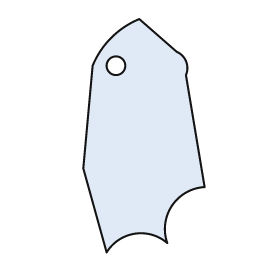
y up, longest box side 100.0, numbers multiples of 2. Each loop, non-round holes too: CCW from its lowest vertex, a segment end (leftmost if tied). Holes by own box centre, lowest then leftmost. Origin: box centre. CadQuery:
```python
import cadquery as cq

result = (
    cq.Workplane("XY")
    .moveTo(-16.0, -50.0)
    .threePointArc((-4.0, -42.0), (10.0, -46.0))
    .threePointArc((12.0, -30.0), (26.0, -22.0))
    .lineTo(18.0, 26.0)
    .threePointArc((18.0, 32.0), (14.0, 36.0))
    .lineTo(-2.0, 50.0)
    .threePointArc((-14.0, 42.0), (-22.0, 30.0))
    .lineTo(-26.0, -14.0)
    .close()
    .moveTo(-12.0, 30.0)
    .circle(4.0)
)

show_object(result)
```